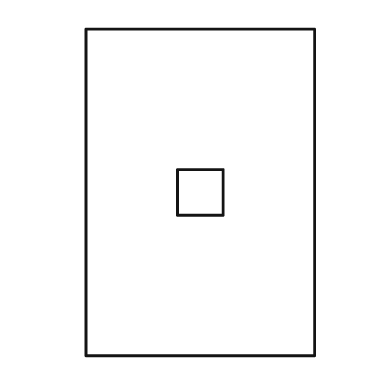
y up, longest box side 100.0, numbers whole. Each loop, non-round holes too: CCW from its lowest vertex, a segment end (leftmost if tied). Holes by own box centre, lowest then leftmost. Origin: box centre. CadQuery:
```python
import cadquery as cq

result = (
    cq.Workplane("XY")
    .moveTo(-35.0, -50.0)
    .lineTo(35.0, -50.0)
    .lineTo(35.0, 50.0)
    .lineTo(-35.0, 50.0)
    .close()
    .moveTo(-7.0, -7.0)
    .lineTo(7.0, -7.0)
    .lineTo(7.0, 7.0)
    .lineTo(-7.0, 7.0)
    .close()
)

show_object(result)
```